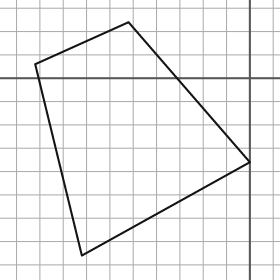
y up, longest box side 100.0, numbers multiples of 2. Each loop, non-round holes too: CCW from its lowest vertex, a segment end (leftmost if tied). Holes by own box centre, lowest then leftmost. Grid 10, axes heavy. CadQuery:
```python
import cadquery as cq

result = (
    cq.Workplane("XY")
    .moveTo(-72.0, -76.0)
    .lineTo(0.0, -36.0)
    .lineTo(-52.0, 24.0)
    .lineTo(-92.0, 6.0)
    .close()
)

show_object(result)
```